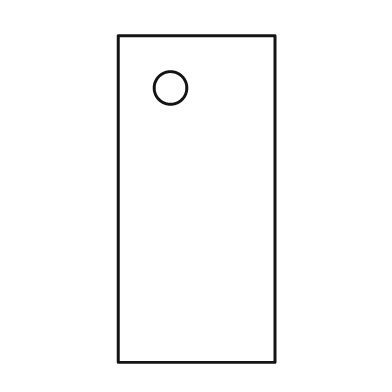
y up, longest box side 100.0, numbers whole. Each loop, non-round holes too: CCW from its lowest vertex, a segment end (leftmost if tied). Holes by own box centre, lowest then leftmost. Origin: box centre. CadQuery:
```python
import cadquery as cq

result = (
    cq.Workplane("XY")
    .moveTo(-24.0, -50.0)
    .lineTo(24.0, -50.0)
    .lineTo(24.0, 50.0)
    .lineTo(-24.0, 50.0)
    .close()
    .moveTo(-8.0, 34.0)
    .circle(5.0)
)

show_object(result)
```